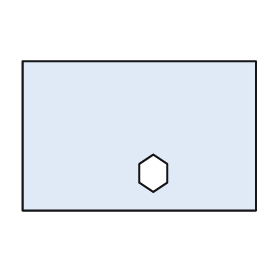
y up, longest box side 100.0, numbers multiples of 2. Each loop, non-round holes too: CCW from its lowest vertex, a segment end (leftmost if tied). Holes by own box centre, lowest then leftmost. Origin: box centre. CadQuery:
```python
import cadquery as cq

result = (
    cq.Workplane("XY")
    .moveTo(-50.0, -32.0)
    .lineTo(50.0, -32.0)
    .lineTo(50.0, 32.0)
    .lineTo(-50.0, 32.0)
    .close()
    .moveTo(6.0, -24.0)
    .lineTo(12.0, -20.0)
    .lineTo(12.0, -12.0)
    .lineTo(6.0, -8.0)
    .lineTo(0.0, -12.0)
    .lineTo(0.0, -20.0)
    .close()
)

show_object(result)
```